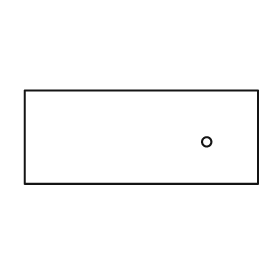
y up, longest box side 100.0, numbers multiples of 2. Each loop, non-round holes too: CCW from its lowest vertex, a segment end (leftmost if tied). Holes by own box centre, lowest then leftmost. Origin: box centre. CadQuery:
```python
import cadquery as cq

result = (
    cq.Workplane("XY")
    .moveTo(-50.0, -20.0)
    .lineTo(50.0, -20.0)
    .lineTo(50.0, 20.0)
    .lineTo(-50.0, 20.0)
    .close()
    .moveTo(28.0, -2.0)
    .circle(2.0)
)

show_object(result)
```